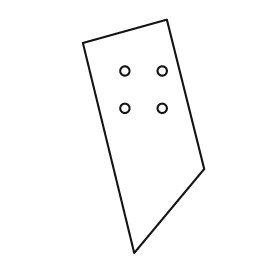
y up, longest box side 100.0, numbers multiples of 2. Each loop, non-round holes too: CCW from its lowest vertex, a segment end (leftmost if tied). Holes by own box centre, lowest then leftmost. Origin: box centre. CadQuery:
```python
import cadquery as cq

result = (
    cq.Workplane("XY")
    .moveTo(-4.0, -50.0)
    .lineTo(26.0, -14.0)
    .lineTo(10.0, 50.0)
    .lineTo(-26.0, 40.0)
    .close()
    .moveTo(-8.0, 12.0)
    .circle(2.0)
    .moveTo(8.0, 12.0)
    .circle(2.0)
    .moveTo(-8.0, 28.0)
    .circle(2.0)
    .moveTo(8.0, 28.0)
    .circle(2.0)
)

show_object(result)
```